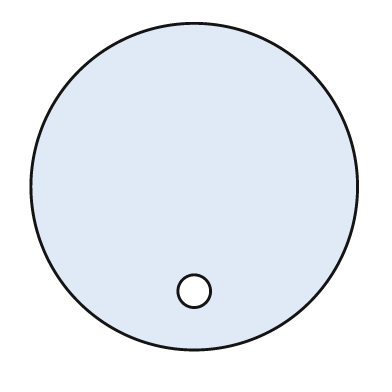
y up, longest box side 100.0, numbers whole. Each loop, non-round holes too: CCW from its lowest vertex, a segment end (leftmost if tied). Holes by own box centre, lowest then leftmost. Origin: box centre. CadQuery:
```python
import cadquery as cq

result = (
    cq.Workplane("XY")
    .moveTo(0.0, 0.0)
    .circle(50.0)
    .moveTo(0.0, -32.0)
    .circle(5.0)
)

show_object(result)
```